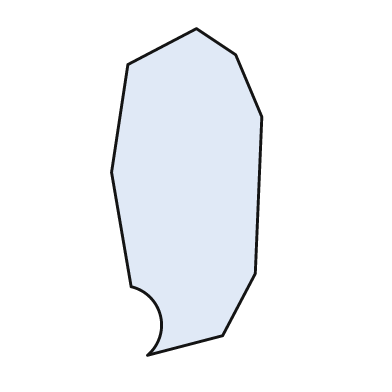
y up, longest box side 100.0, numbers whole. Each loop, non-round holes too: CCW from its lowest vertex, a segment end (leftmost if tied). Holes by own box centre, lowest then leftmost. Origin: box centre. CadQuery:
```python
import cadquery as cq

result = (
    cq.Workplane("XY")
    .moveTo(-12.0, -50.0)
    .lineTo(11.0, -44.0)
    .lineTo(21.0, -25.0)
    .lineTo(23.0, 23.0)
    .lineTo(15.0, 42.0)
    .lineTo(3.0, 50.0)
    .lineTo(-18.0, 39.0)
    .lineTo(-23.0, 6.0)
    .lineTo(-17.0, -29.0)
    .threePointArc((-8.0, -38.0), (-12.0, -50.0))
    .close()
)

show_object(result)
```